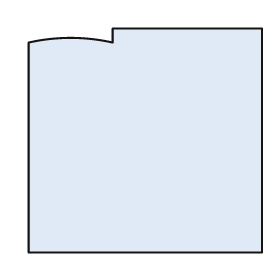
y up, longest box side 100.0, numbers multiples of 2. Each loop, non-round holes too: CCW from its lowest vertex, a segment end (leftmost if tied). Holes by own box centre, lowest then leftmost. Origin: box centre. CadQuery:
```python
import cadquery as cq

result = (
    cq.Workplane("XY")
    .moveTo(-50.0, -48.0)
    .lineTo(50.0, -48.0)
    .lineTo(50.0, 48.0)
    .lineTo(-14.0, 48.0)
    .lineTo(-14.0, 42.0)
    .threePointArc((-32.0, 44.0), (-50.0, 42.0))
    .close()
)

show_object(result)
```